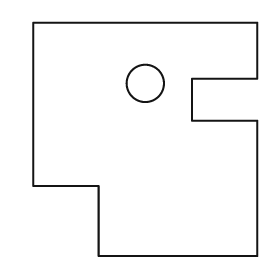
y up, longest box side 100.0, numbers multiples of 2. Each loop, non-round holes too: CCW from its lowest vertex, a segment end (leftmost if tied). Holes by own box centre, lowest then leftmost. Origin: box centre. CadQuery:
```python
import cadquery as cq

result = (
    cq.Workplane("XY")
    .moveTo(-20.0, -50.0)
    .lineTo(48.0, -50.0)
    .lineTo(48.0, 8.0)
    .lineTo(20.0, 8.0)
    .lineTo(20.0, 26.0)
    .lineTo(48.0, 26.0)
    .lineTo(48.0, 50.0)
    .lineTo(-48.0, 50.0)
    .lineTo(-48.0, -20.0)
    .lineTo(-20.0, -20.0)
    .close()
    .moveTo(0.0, 24.0)
    .circle(8.0)
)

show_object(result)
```